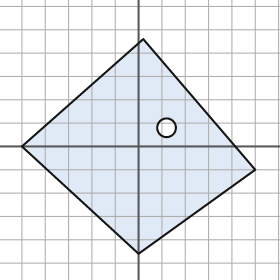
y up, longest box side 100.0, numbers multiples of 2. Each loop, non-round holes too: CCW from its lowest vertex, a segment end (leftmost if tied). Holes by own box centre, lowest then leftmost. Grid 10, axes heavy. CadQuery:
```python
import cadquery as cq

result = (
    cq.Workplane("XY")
    .moveTo(0.0, -46.0)
    .lineTo(50.0, -10.0)
    .lineTo(2.0, 46.0)
    .lineTo(-50.0, 0.0)
    .close()
    .moveTo(12.0, 8.0)
    .circle(4.0)
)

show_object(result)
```